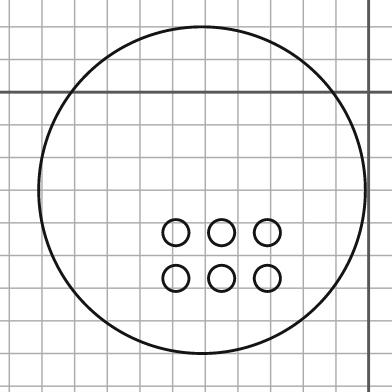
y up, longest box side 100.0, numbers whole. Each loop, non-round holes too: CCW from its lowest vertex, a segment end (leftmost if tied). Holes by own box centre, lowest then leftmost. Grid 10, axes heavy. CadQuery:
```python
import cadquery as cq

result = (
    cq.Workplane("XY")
    .moveTo(-51.0, -30.0)
    .circle(50.0)
    .moveTo(-59.0, -57.0)
    .circle(4.0)
    .moveTo(-45.0, -57.0)
    .circle(4.0)
    .moveTo(-31.0, -57.0)
    .circle(4.0)
    .moveTo(-59.0, -43.0)
    .circle(4.0)
    .moveTo(-45.0, -43.0)
    .circle(4.0)
    .moveTo(-31.0, -43.0)
    .circle(4.0)
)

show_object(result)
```